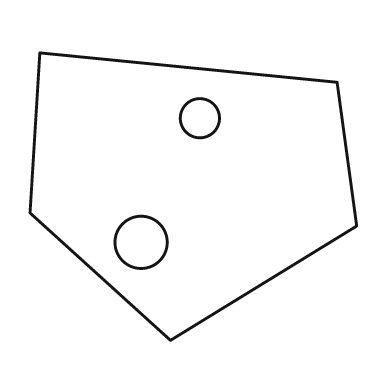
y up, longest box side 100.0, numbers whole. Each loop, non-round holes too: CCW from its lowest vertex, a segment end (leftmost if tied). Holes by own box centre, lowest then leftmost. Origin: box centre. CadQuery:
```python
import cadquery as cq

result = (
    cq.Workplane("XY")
    .moveTo(-7.0, -44.0)
    .lineTo(50.0, -9.0)
    .lineTo(44.0, 35.0)
    .lineTo(-47.0, 44.0)
    .lineTo(-50.0, -5.0)
    .close()
    .moveTo(-16.0, -14.0)
    .circle(8.0)
    .moveTo(2.0, 24.0)
    .circle(6.0)
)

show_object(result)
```